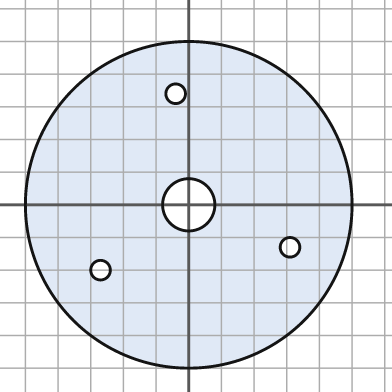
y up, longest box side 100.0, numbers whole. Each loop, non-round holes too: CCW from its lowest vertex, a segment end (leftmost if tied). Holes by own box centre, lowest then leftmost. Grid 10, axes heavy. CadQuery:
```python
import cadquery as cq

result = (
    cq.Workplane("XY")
    .moveTo(0.0, 0.0)
    .circle(50.0)
    .moveTo(-27.0, -20.0)
    .circle(3.0)
    .moveTo(31.0, -13.0)
    .circle(3.0)
    .moveTo(0.0, 0.0)
    .circle(8.0)
    .moveTo(-4.0, 34.0)
    .circle(3.0)
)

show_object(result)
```